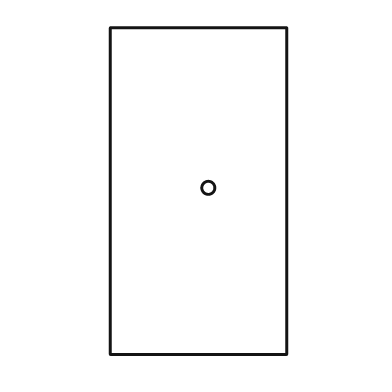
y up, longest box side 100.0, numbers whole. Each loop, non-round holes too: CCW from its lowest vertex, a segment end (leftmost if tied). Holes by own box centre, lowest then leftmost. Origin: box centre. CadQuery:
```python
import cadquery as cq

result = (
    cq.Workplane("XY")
    .moveTo(-27.0, -50.0)
    .lineTo(27.0, -50.0)
    .lineTo(27.0, 50.0)
    .lineTo(-27.0, 50.0)
    .close()
    .moveTo(3.0, 1.0)
    .circle(2.0)
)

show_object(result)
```